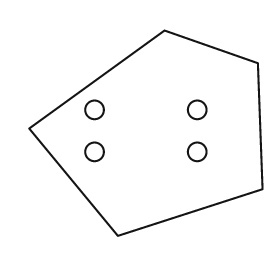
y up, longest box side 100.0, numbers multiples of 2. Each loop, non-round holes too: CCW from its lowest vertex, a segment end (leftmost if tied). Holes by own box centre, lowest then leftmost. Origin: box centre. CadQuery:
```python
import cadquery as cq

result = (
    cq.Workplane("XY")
    .moveTo(-12.0, -44.0)
    .lineTo(50.0, -24.0)
    .lineTo(48.0, 30.0)
    .lineTo(8.0, 44.0)
    .lineTo(-50.0, 2.0)
    .close()
    .moveTo(-22.0, -8.0)
    .circle(4.0)
    .moveTo(22.0, -8.0)
    .circle(4.0)
    .moveTo(-22.0, 10.0)
    .circle(4.0)
    .moveTo(22.0, 10.0)
    .circle(4.0)
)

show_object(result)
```